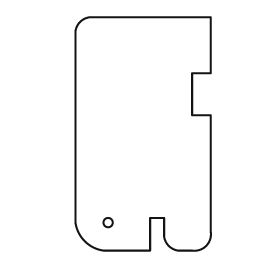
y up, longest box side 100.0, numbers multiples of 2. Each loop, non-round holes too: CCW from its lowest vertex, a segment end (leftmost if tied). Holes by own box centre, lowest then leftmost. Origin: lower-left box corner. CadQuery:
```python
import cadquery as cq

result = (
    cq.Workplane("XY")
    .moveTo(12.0, 0.0)
    .lineTo(32.0, 0.0)
    .lineTo(32.0, 14.0)
    .lineTo(38.0, 14.0)
    .lineTo(38.0, 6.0)
    .threePointArc((40.0, 2.0), (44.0, 0.0))
    .lineTo(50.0, 0.0)
    .threePointArc((56.0, 2.0), (58.0, 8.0))
    .lineTo(58.0, 58.0)
    .lineTo(50.0, 58.0)
    .lineTo(50.0, 76.0)
    .lineTo(58.0, 76.0)
    .lineTo(58.0, 100.0)
    .lineTo(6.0, 100.0)
    .threePointArc((2.0, 98.0), (0.0, 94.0))
    .lineTo(0.0, 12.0)
    .threePointArc((4.0, 4.0), (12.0, 0.0))
    .close()
    .moveTo(14.0, 12.0)
    .circle(2.0)
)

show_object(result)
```